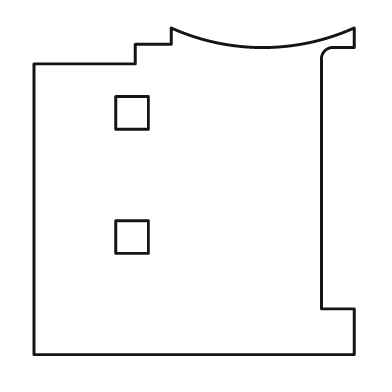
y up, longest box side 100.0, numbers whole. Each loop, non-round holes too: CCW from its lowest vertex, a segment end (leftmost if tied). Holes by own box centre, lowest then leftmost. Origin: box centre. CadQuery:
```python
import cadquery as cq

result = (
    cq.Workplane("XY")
    .moveTo(-49.0, -50.0)
    .lineTo(49.0, -50.0)
    .lineTo(49.0, -36.0)
    .lineTo(39.0, -36.0)
    .lineTo(39.0, 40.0)
    .threePointArc((40.0, 43.0), (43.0, 44.0))
    .lineTo(49.0, 44.0)
    .lineTo(49.0, 50.0)
    .threePointArc((21.0, 44.0), (-7.0, 50.0))
    .lineTo(-7.0, 45.0)
    .lineTo(-18.0, 45.0)
    .lineTo(-18.0, 39.0)
    .lineTo(-49.0, 39.0)
    .close()
    .moveTo(-24.0, -19.0)
    .lineTo(-14.0, -19.0)
    .lineTo(-14.0, -9.0)
    .lineTo(-24.0, -9.0)
    .close()
    .moveTo(-24.0, 19.0)
    .lineTo(-14.0, 19.0)
    .lineTo(-14.0, 29.0)
    .lineTo(-24.0, 29.0)
    .close()
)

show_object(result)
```